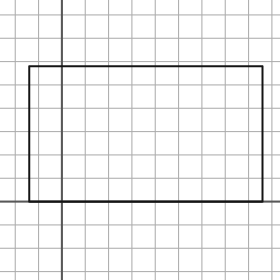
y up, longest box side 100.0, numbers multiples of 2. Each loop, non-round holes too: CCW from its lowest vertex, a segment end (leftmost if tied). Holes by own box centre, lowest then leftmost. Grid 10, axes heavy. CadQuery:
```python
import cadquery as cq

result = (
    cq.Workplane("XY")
    .moveTo(-14.0, 0.0)
    .lineTo(86.0, 0.0)
    .lineTo(86.0, 58.0)
    .lineTo(-14.0, 58.0)
    .close()
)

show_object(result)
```